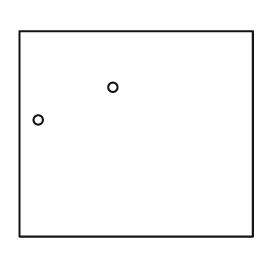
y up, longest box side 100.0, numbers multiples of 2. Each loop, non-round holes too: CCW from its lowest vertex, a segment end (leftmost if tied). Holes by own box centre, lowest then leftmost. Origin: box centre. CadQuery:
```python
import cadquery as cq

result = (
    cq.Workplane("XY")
    .moveTo(-50.0, -44.0)
    .lineTo(50.0, -44.0)
    .lineTo(50.0, 44.0)
    .lineTo(-50.0, 44.0)
    .close()
    .moveTo(-42.0, 6.0)
    .circle(2.0)
    .moveTo(-10.0, 20.0)
    .circle(2.0)
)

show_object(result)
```